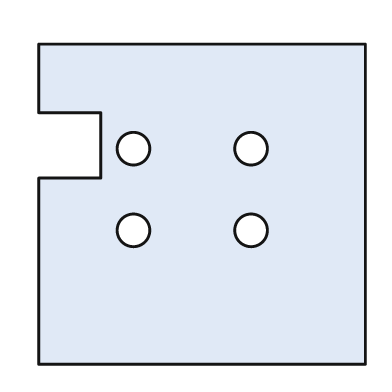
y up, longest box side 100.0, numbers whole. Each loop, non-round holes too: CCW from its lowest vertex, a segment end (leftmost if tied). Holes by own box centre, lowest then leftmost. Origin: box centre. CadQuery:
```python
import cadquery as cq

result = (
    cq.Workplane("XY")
    .moveTo(-50.0, -49.0)
    .lineTo(50.0, -49.0)
    .lineTo(50.0, 49.0)
    .lineTo(-50.0, 49.0)
    .lineTo(-50.0, 28.0)
    .lineTo(-31.0, 28.0)
    .lineTo(-31.0, 8.0)
    .lineTo(-50.0, 8.0)
    .close()
    .moveTo(-21.0, -8.0)
    .circle(5.0)
    .moveTo(15.0, -8.0)
    .circle(5.0)
    .moveTo(-21.0, 17.0)
    .circle(5.0)
    .moveTo(15.0, 17.0)
    .circle(5.0)
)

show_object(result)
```